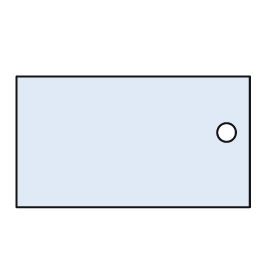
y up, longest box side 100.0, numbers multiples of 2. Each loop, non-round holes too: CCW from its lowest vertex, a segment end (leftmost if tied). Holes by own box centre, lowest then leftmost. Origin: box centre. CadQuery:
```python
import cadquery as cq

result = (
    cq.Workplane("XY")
    .moveTo(-50.0, -28.0)
    .lineTo(50.0, -28.0)
    .lineTo(50.0, 28.0)
    .lineTo(-50.0, 28.0)
    .close()
    .moveTo(40.0, 4.0)
    .circle(4.0)
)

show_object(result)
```